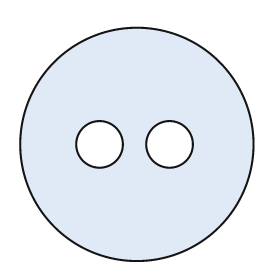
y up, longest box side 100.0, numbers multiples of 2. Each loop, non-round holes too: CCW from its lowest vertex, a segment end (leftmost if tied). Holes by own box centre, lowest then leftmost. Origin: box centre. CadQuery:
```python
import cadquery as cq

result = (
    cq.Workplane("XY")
    .moveTo(0.0, 0.0)
    .circle(50.0)
    .moveTo(-16.0, 0.0)
    .circle(10.0)
    .moveTo(14.0, 0.0)
    .circle(10.0)
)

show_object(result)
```